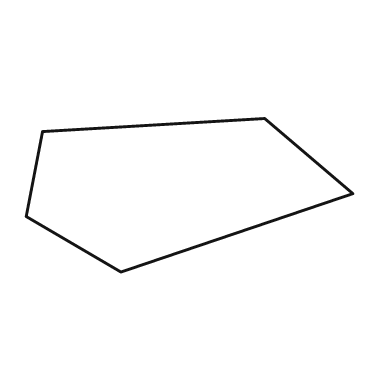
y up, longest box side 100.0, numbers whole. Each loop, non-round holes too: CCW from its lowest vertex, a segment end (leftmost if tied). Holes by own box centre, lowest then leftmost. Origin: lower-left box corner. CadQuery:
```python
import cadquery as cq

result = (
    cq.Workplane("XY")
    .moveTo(29.0, 0.0)
    .lineTo(100.0, 24.0)
    .lineTo(73.0, 47.0)
    .lineTo(5.0, 43.0)
    .lineTo(0.0, 17.0)
    .close()
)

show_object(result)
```